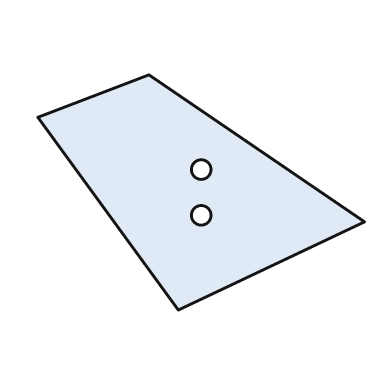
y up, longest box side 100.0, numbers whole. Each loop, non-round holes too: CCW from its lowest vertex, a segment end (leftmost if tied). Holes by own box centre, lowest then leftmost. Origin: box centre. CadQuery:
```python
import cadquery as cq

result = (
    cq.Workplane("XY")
    .moveTo(-7.0, -36.0)
    .lineTo(50.0, -9.0)
    .lineTo(-16.0, 36.0)
    .lineTo(-50.0, 23.0)
    .close()
    .moveTo(0.0, -7.0)
    .circle(3.0)
    .moveTo(0.0, 7.0)
    .circle(3.0)
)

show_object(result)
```